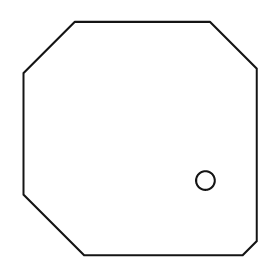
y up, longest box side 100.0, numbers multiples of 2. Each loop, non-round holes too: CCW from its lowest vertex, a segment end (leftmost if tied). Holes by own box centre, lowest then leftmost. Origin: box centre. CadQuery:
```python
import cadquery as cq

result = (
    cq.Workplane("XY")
    .moveTo(-24.0, -50.0)
    .lineTo(44.0, -50.0)
    .lineTo(50.0, -44.0)
    .lineTo(50.0, 30.0)
    .lineTo(30.0, 50.0)
    .lineTo(-28.0, 50.0)
    .lineTo(-50.0, 28.0)
    .lineTo(-50.0, -24.0)
    .close()
    .moveTo(28.0, -18.0)
    .circle(4.0)
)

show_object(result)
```